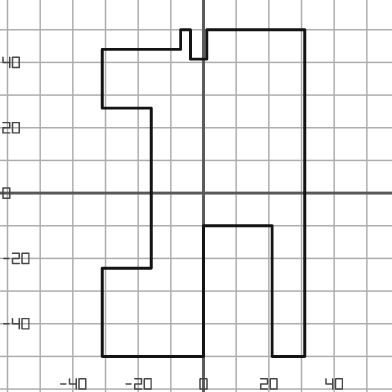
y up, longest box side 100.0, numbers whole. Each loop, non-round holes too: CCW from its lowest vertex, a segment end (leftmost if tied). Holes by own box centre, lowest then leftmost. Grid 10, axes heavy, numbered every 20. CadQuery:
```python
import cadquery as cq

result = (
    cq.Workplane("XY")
    .moveTo(-31.0, -50.0)
    .lineTo(0.0, -50.0)
    .lineTo(0.0, -10.0)
    .lineTo(21.0, -10.0)
    .lineTo(21.0, -50.0)
    .lineTo(31.0, -50.0)
    .lineTo(31.0, 50.0)
    .lineTo(1.0, 50.0)
    .lineTo(1.0, 41.0)
    .lineTo(-4.0, 41.0)
    .lineTo(-4.0, 50.0)
    .lineTo(-7.0, 50.0)
    .lineTo(-7.0, 44.0)
    .lineTo(-31.0, 44.0)
    .lineTo(-31.0, 26.0)
    .lineTo(-16.0, 26.0)
    .lineTo(-16.0, -23.0)
    .lineTo(-31.0, -23.0)
    .close()
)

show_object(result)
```